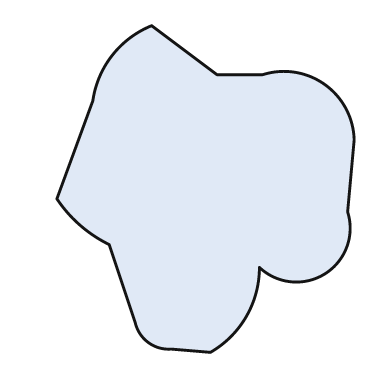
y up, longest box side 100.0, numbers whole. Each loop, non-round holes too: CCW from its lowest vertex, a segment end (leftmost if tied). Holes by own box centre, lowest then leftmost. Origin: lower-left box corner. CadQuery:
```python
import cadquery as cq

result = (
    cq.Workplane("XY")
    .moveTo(47.0, 0.0)
    .threePointArc((58.0, 11.0), (62.0, 26.0))
    .threePointArc((82.0, 24.0), (89.0, 43.0))
    .lineTo(91.0, 65.0)
    .threePointArc((82.0, 82.0), (63.0, 85.0))
    .lineTo(49.0, 85.0)
    .lineTo(29.0, 100.0)
    .threePointArc((17.0, 91.0), (11.0, 77.0))
    .lineTo(0.0, 47.0)
    .threePointArc((7.0, 39.0), (16.0, 33.0))
    .lineTo(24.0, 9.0)
    .threePointArc((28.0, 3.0), (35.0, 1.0))
    .close()
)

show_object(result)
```